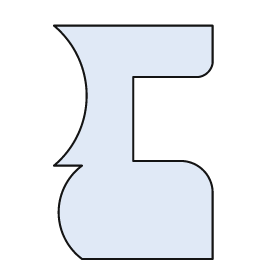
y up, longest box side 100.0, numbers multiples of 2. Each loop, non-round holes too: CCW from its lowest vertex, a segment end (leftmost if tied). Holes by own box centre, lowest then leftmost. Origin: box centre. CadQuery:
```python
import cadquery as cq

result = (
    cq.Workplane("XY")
    .moveTo(-22.0, -50.0)
    .lineTo(34.0, -50.0)
    .lineTo(34.0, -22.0)
    .threePointArc((30.0, -12.0), (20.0, -8.0))
    .lineTo(0.0, -8.0)
    .lineTo(0.0, 28.0)
    .lineTo(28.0, 28.0)
    .threePointArc((32.0, 30.0), (34.0, 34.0))
    .lineTo(34.0, 50.0)
    .lineTo(-34.0, 50.0)
    .threePointArc((-20.0, 20.0), (-34.0, -10.0))
    .lineTo(-22.0, -10.0)
    .threePointArc((-32.0, -30.0), (-22.0, -50.0))
    .close()
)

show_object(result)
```